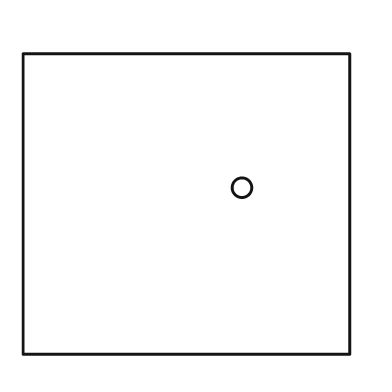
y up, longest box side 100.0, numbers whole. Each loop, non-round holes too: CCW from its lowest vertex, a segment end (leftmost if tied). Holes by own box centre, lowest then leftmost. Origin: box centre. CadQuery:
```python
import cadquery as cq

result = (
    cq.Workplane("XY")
    .moveTo(-50.0, -46.0)
    .lineTo(50.0, -46.0)
    .lineTo(50.0, 46.0)
    .lineTo(-50.0, 46.0)
    .close()
    .moveTo(17.0, 5.0)
    .circle(3.0)
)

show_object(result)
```